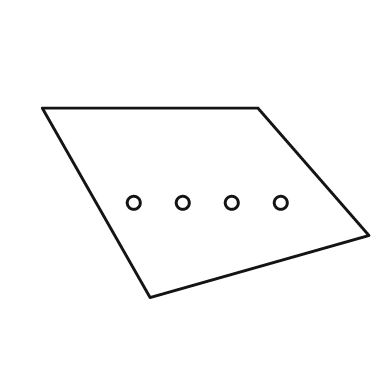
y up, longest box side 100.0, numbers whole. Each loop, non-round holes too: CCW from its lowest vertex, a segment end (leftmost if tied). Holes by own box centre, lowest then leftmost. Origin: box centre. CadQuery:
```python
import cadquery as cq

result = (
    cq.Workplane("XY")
    .moveTo(-17.0, -29.0)
    .lineTo(50.0, -10.0)
    .lineTo(16.0, 29.0)
    .lineTo(-50.0, 29.0)
    .close()
    .moveTo(-22.0, 0.0)
    .circle(2.0)
    .moveTo(-7.0, 0.0)
    .circle(2.0)
    .moveTo(8.0, 0.0)
    .circle(2.0)
    .moveTo(23.0, 0.0)
    .circle(2.0)
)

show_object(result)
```